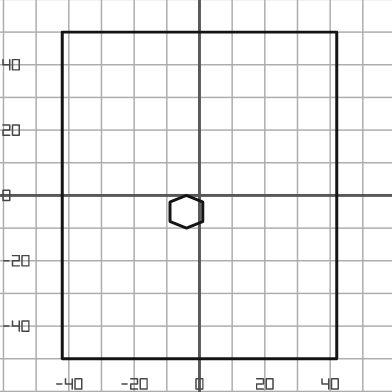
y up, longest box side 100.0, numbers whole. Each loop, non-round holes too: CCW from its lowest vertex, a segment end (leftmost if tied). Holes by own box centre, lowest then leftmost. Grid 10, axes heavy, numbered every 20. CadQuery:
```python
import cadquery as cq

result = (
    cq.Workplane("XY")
    .moveTo(-42.0, -50.0)
    .lineTo(42.0, -50.0)
    .lineTo(42.0, 50.0)
    .lineTo(-42.0, 50.0)
    .close()
    .moveTo(-4.0, -10.0)
    .lineTo(1.0, -8.0)
    .lineTo(1.0, -2.0)
    .lineTo(-4.0, 0.0)
    .lineTo(-9.0, -2.0)
    .lineTo(-9.0, -8.0)
    .close()
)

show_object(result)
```